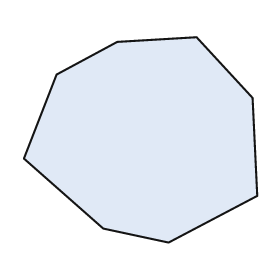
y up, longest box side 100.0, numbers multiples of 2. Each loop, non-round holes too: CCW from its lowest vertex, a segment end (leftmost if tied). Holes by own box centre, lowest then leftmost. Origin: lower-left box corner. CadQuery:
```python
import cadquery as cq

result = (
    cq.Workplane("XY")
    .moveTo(62.0, 0.0)
    .lineTo(100.0, 20.0)
    .lineTo(98.0, 62.0)
    .lineTo(74.0, 88.0)
    .lineTo(40.0, 86.0)
    .lineTo(14.0, 72.0)
    .lineTo(0.0, 36.0)
    .lineTo(34.0, 6.0)
    .close()
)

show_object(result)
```